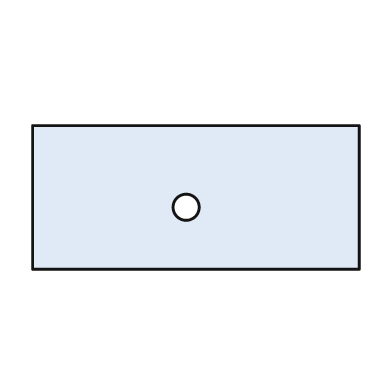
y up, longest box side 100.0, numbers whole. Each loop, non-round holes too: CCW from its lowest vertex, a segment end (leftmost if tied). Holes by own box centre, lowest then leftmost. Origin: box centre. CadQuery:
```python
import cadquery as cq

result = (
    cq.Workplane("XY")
    .moveTo(-50.0, -22.0)
    .lineTo(50.0, -22.0)
    .lineTo(50.0, 22.0)
    .lineTo(-50.0, 22.0)
    .close()
    .moveTo(-3.0, -3.0)
    .circle(4.0)
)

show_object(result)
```